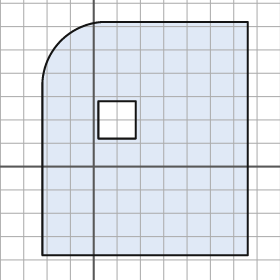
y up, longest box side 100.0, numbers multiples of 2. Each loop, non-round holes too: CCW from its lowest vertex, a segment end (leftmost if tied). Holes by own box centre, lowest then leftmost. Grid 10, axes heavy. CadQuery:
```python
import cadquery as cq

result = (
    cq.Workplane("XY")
    .moveTo(-22.0, -38.0)
    .lineTo(66.0, -38.0)
    .lineTo(66.0, 62.0)
    .lineTo(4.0, 62.0)
    .threePointArc((-14.0, 54.0), (-22.0, 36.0))
    .close()
    .moveTo(2.0, 12.0)
    .lineTo(18.0, 12.0)
    .lineTo(18.0, 28.0)
    .lineTo(2.0, 28.0)
    .close()
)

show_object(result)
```